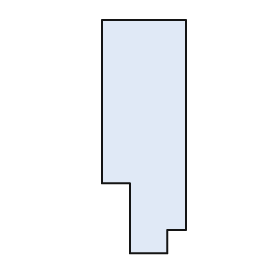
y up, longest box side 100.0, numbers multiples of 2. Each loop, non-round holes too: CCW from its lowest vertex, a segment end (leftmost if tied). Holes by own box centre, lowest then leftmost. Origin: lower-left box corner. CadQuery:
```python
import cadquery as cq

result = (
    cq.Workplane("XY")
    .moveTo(12.0, 0.0)
    .lineTo(28.0, 0.0)
    .lineTo(28.0, 10.0)
    .lineTo(36.0, 10.0)
    .lineTo(36.0, 100.0)
    .lineTo(0.0, 100.0)
    .lineTo(0.0, 30.0)
    .lineTo(12.0, 30.0)
    .close()
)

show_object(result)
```